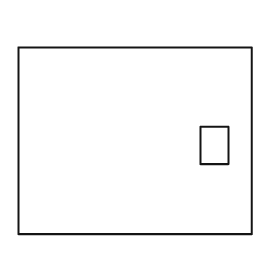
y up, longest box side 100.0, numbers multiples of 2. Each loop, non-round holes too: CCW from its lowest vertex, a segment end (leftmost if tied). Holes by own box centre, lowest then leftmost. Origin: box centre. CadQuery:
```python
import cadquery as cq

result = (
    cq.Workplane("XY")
    .moveTo(-50.0, -40.0)
    .lineTo(50.0, -40.0)
    .lineTo(50.0, 40.0)
    .lineTo(-50.0, 40.0)
    .close()
    .moveTo(28.0, -10.0)
    .lineTo(40.0, -10.0)
    .lineTo(40.0, 6.0)
    .lineTo(28.0, 6.0)
    .close()
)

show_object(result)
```